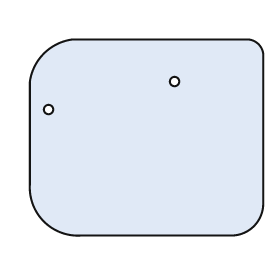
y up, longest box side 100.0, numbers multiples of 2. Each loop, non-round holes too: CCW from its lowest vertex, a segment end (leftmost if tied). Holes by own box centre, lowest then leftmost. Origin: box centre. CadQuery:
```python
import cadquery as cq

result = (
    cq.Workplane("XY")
    .moveTo(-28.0, -42.0)
    .lineTo(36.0, -42.0)
    .threePointArc((46.0, -38.0), (50.0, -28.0))
    .lineTo(50.0, 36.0)
    .threePointArc((48.0, 40.0), (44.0, 42.0))
    .lineTo(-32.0, 42.0)
    .threePointArc((-44.0, 36.0), (-50.0, 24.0))
    .lineTo(-50.0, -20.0)
    .threePointArc((-44.0, -36.0), (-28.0, -42.0))
    .close()
    .moveTo(-42.0, 12.0)
    .circle(2.0)
    .moveTo(12.0, 24.0)
    .circle(2.0)
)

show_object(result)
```